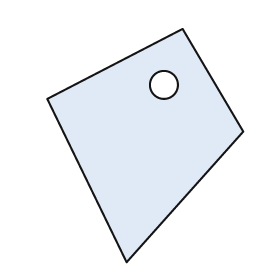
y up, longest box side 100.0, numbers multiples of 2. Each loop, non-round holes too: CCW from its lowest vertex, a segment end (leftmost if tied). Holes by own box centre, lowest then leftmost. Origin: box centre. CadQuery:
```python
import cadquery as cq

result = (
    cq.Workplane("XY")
    .moveTo(-8.0, -50.0)
    .lineTo(42.0, 6.0)
    .lineTo(16.0, 50.0)
    .lineTo(-42.0, 20.0)
    .close()
    .moveTo(8.0, 26.0)
    .circle(6.0)
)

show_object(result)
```